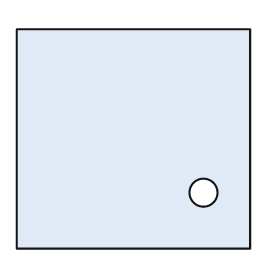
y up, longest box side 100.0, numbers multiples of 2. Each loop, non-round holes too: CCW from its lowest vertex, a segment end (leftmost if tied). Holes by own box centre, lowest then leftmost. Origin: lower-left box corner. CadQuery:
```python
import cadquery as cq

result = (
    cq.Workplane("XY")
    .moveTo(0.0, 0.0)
    .lineTo(100.0, 0.0)
    .lineTo(100.0, 94.0)
    .lineTo(0.0, 94.0)
    .close()
    .moveTo(80.0, 24.0)
    .circle(6.0)
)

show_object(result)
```